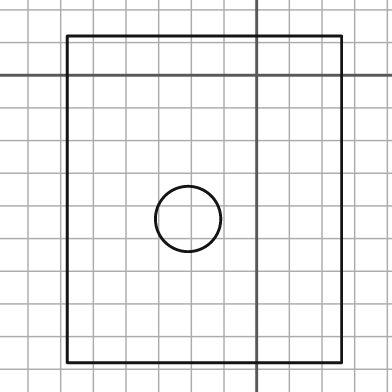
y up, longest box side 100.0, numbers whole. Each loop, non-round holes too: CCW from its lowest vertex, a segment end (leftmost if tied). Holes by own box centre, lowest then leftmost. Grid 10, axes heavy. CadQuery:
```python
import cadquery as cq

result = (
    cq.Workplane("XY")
    .moveTo(-58.0, -88.0)
    .lineTo(26.0, -88.0)
    .lineTo(26.0, 12.0)
    .lineTo(-58.0, 12.0)
    .close()
    .moveTo(-21.0, -44.0)
    .circle(10.0)
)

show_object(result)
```